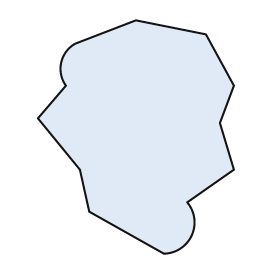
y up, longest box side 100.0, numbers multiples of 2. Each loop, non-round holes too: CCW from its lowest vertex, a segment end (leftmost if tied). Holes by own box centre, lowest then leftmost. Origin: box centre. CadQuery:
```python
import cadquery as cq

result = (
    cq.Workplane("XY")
    .moveTo(12.0, -50.0)
    .threePointArc((24.0, -42.0), (22.0, -28.0))
    .lineTo(42.0, -14.0)
    .lineTo(36.0, 6.0)
    .lineTo(42.0, 22.0)
    .lineTo(30.0, 44.0)
    .lineTo(0.0, 50.0)
    .lineTo(-26.0, 40.0)
    .threePointArc((-32.0, 32.0), (-30.0, 22.0))
    .lineTo(-42.0, 8.0)
    .lineTo(-24.0, -14.0)
    .lineTo(-20.0, -32.0)
    .close()
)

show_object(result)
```